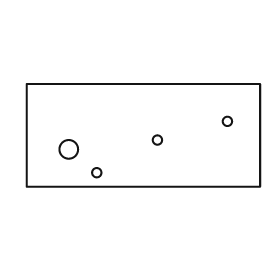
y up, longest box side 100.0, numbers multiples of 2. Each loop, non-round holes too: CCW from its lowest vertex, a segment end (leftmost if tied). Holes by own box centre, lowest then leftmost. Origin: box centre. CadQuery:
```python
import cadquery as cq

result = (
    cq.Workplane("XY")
    .moveTo(-50.0, -22.0)
    .lineTo(50.0, -22.0)
    .lineTo(50.0, 22.0)
    .lineTo(-50.0, 22.0)
    .close()
    .moveTo(-20.0, -16.0)
    .circle(2.0)
    .moveTo(-32.0, -6.0)
    .circle(4.0)
    .moveTo(6.0, -2.0)
    .circle(2.0)
    .moveTo(36.0, 6.0)
    .circle(2.0)
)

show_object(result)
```